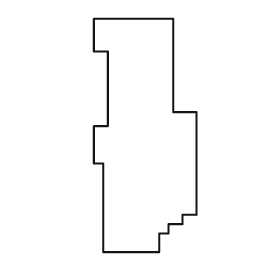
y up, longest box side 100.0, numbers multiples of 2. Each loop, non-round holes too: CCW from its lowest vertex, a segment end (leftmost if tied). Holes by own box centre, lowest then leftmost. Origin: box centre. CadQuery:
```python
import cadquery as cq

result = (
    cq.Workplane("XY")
    .moveTo(-18.0, -50.0)
    .lineTo(6.0, -50.0)
    .lineTo(6.0, -42.0)
    .lineTo(10.0, -42.0)
    .lineTo(10.0, -38.0)
    .lineTo(16.0, -38.0)
    .lineTo(16.0, -34.0)
    .lineTo(22.0, -34.0)
    .lineTo(22.0, 10.0)
    .lineTo(12.0, 10.0)
    .lineTo(12.0, 50.0)
    .lineTo(-22.0, 50.0)
    .lineTo(-22.0, 36.0)
    .lineTo(-16.0, 36.0)
    .lineTo(-16.0, 4.0)
    .lineTo(-22.0, 4.0)
    .lineTo(-22.0, -12.0)
    .lineTo(-18.0, -12.0)
    .close()
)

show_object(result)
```